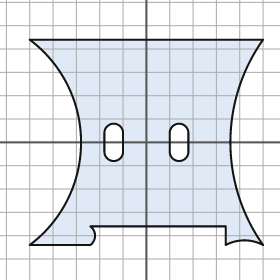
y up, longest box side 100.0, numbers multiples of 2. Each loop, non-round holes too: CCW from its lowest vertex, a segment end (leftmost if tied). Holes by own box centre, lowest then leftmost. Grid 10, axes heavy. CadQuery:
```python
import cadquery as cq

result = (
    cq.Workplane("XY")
    .moveTo(-50.0, -44.0)
    .lineTo(-24.0, -44.0)
    .threePointArc((-22.0, -40.0), (-24.0, -36.0))
    .lineTo(34.0, -36.0)
    .lineTo(34.0, -44.0)
    .threePointArc((42.0, -42.0), (50.0, -44.0))
    .threePointArc((36.0, 0.0), (50.0, 44.0))
    .lineTo(-50.0, 44.0)
    .threePointArc((-28.0, 0.0), (-50.0, -44.0))
    .close()
    .moveTo(-18.0, -4.0)
    .threePointArc((-14.0, -8.0), (-10.0, -4.0))
    .lineTo(-10.0, 4.0)
    .threePointArc((-14.0, 8.0), (-18.0, 4.0))
    .close()
    .moveTo(10.0, -4.0)
    .threePointArc((14.0, -8.0), (18.0, -4.0))
    .lineTo(18.0, 4.0)
    .threePointArc((14.0, 8.0), (10.0, 4.0))
    .close()
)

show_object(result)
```